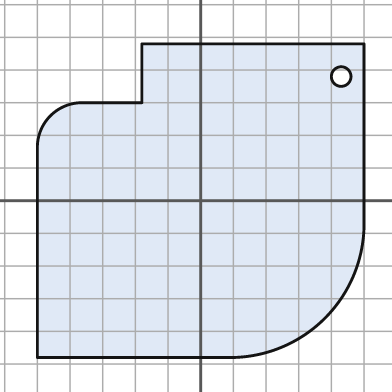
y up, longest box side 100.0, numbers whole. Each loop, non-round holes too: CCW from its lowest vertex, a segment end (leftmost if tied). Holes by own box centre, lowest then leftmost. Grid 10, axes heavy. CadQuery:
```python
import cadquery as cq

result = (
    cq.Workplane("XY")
    .moveTo(-50.0, -48.0)
    .lineTo(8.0, -48.0)
    .threePointArc((38.0, -36.0), (50.0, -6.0))
    .lineTo(50.0, 48.0)
    .lineTo(-18.0, 48.0)
    .lineTo(-18.0, 30.0)
    .lineTo(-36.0, 30.0)
    .threePointArc((-46.0, 26.0), (-50.0, 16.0))
    .close()
    .moveTo(43.0, 38.0)
    .circle(3.0)
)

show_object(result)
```